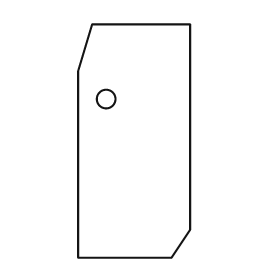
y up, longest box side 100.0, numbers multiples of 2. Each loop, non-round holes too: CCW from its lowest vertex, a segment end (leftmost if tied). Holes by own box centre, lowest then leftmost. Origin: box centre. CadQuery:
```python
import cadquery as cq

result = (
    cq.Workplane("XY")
    .moveTo(-24.0, -50.0)
    .lineTo(16.0, -50.0)
    .lineTo(24.0, -38.0)
    .lineTo(24.0, 50.0)
    .lineTo(-18.0, 50.0)
    .lineTo(-24.0, 30.0)
    .close()
    .moveTo(-12.0, 18.0)
    .circle(4.0)
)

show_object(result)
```